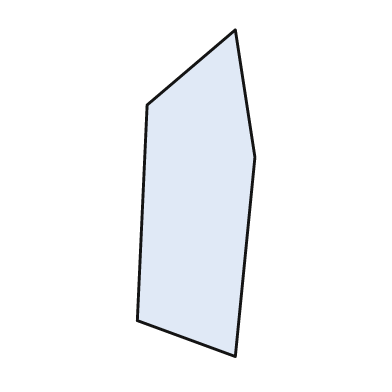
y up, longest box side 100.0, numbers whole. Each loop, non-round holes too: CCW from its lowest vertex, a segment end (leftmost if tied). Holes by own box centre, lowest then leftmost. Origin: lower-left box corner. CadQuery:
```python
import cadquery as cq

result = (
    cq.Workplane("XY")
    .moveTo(30.0, 0.0)
    .lineTo(36.0, 61.0)
    .lineTo(30.0, 100.0)
    .lineTo(3.0, 77.0)
    .lineTo(0.0, 11.0)
    .close()
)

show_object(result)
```